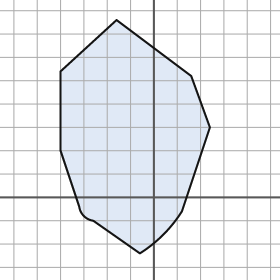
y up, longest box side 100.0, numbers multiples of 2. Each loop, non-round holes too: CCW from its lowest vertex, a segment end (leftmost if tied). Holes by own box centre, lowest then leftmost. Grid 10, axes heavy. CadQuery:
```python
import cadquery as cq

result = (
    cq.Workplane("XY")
    .moveTo(-6.0, -24.0)
    .threePointArc((4.0, -16.0), (12.0, -6.0))
    .lineTo(24.0, 30.0)
    .lineTo(16.0, 52.0)
    .lineTo(-16.0, 76.0)
    .lineTo(-40.0, 54.0)
    .lineTo(-40.0, 20.0)
    .lineTo(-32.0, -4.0)
    .threePointArc((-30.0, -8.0), (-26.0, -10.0))
    .close()
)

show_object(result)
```